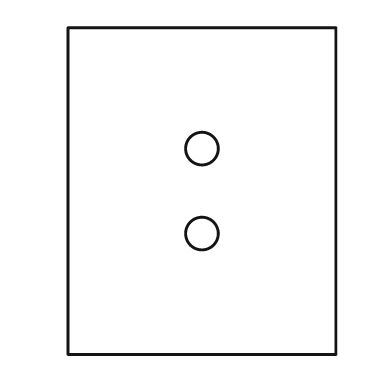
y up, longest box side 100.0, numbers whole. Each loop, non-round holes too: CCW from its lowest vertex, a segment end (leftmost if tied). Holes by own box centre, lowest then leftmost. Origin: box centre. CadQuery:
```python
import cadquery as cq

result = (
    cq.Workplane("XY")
    .moveTo(-41.0, -50.0)
    .lineTo(41.0, -50.0)
    .lineTo(41.0, 50.0)
    .lineTo(-41.0, 50.0)
    .close()
    .moveTo(0.0, -13.0)
    .circle(5.0)
    .moveTo(0.0, 13.0)
    .circle(5.0)
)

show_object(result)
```